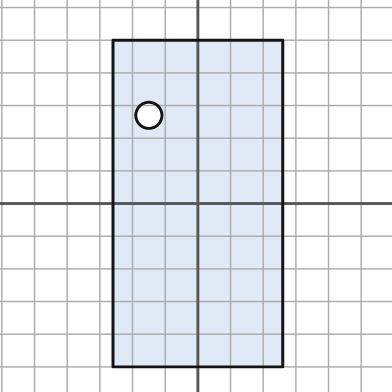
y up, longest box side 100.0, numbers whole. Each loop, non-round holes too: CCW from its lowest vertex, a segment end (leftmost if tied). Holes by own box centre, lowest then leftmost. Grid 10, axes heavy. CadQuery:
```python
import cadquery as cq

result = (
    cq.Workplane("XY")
    .moveTo(-26.0, -50.0)
    .lineTo(26.0, -50.0)
    .lineTo(26.0, 50.0)
    .lineTo(-26.0, 50.0)
    .close()
    .moveTo(-15.0, 27.0)
    .circle(4.0)
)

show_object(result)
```